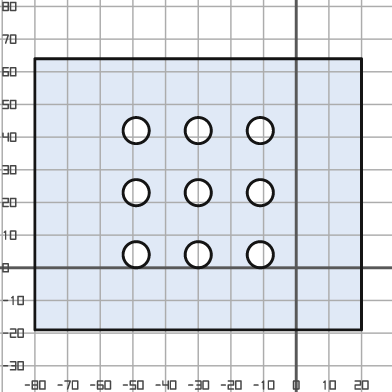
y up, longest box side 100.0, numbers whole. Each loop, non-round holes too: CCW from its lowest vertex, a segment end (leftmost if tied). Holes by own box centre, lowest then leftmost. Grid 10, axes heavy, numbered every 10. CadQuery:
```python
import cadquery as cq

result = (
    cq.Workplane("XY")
    .moveTo(-80.0, -19.0)
    .lineTo(20.0, -19.0)
    .lineTo(20.0, 64.0)
    .lineTo(-80.0, 64.0)
    .close()
    .moveTo(-49.0, 4.0)
    .circle(4.0)
    .moveTo(-30.0, 4.0)
    .circle(4.0)
    .moveTo(-11.0, 4.0)
    .circle(4.0)
    .moveTo(-49.0, 23.0)
    .circle(4.0)
    .moveTo(-30.0, 23.0)
    .circle(4.0)
    .moveTo(-11.0, 23.0)
    .circle(4.0)
    .moveTo(-49.0, 42.0)
    .circle(4.0)
    .moveTo(-30.0, 42.0)
    .circle(4.0)
    .moveTo(-11.0, 42.0)
    .circle(4.0)
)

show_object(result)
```